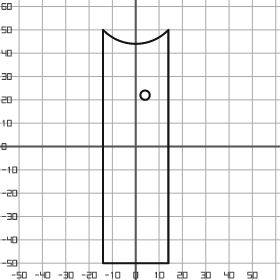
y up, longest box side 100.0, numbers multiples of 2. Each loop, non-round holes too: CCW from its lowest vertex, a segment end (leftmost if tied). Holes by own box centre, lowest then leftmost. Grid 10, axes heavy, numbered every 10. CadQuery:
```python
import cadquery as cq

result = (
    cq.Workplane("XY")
    .moveTo(-14.0, -50.0)
    .lineTo(14.0, -50.0)
    .lineTo(14.0, 50.0)
    .threePointArc((0.0, 44.0), (-14.0, 50.0))
    .close()
    .moveTo(4.0, 22.0)
    .circle(2.0)
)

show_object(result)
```